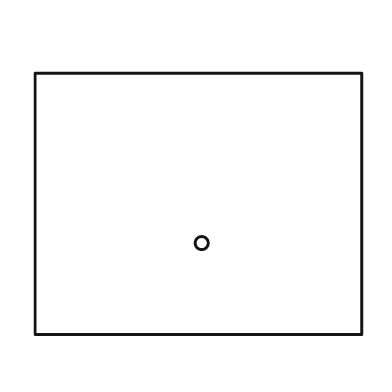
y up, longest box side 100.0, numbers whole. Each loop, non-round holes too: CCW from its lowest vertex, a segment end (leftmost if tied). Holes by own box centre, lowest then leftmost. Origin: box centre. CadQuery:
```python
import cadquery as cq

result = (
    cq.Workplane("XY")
    .moveTo(-50.0, -40.0)
    .lineTo(50.0, -40.0)
    .lineTo(50.0, 40.0)
    .lineTo(-50.0, 40.0)
    .close()
    .moveTo(1.0, -12.0)
    .circle(2.0)
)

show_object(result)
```